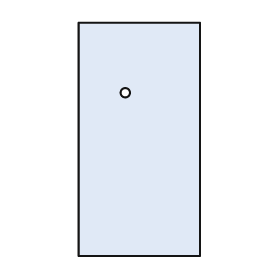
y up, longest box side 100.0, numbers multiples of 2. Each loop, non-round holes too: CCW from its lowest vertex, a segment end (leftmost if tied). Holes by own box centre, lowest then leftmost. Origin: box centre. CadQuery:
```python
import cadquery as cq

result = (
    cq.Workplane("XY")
    .moveTo(-26.0, -50.0)
    .lineTo(26.0, -50.0)
    .lineTo(26.0, 50.0)
    .lineTo(-26.0, 50.0)
    .close()
    .moveTo(-6.0, 20.0)
    .circle(2.0)
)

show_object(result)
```